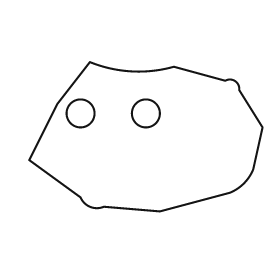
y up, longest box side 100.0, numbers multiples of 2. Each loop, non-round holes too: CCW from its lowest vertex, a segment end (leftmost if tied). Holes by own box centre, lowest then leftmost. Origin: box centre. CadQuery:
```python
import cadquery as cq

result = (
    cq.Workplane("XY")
    .moveTo(6.0, -32.0)
    .lineTo(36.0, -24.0)
    .threePointArc((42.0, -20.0), (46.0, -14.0))
    .lineTo(50.0, 4.0)
    .lineTo(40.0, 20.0)
    .threePointArc((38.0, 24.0), (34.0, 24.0))
    .lineTo(12.0, 30.0)
    .threePointArc((-6.0, 28.0), (-24.0, 32.0))
    .lineTo(-38.0, 14.0)
    .lineTo(-50.0, -10.0)
    .lineTo(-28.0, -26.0)
    .threePointArc((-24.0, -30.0), (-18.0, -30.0))
    .close()
    .moveTo(-28.0, 10.0)
    .circle(6.0)
    .moveTo(0.0, 10.0)
    .circle(6.0)
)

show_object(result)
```